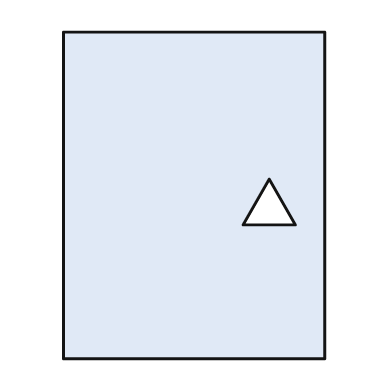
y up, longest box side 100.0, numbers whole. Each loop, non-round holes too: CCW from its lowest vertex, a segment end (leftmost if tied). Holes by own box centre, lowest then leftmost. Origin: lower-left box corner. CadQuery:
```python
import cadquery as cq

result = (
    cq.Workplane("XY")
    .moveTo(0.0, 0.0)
    .lineTo(80.0, 0.0)
    .lineTo(80.0, 100.0)
    .lineTo(0.0, 100.0)
    .close()
    .moveTo(55.0, 41.0)
    .lineTo(71.0, 41.0)
    .lineTo(63.0, 55.0)
    .close()
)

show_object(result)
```